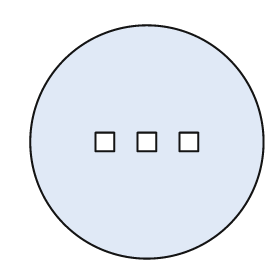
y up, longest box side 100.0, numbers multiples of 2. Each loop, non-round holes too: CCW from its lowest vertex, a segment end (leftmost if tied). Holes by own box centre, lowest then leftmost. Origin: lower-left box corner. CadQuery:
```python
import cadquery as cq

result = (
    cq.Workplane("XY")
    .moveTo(50.0, 50.0)
    .circle(50.0)
    .moveTo(28.0, 46.0)
    .lineTo(36.0, 46.0)
    .lineTo(36.0, 54.0)
    .lineTo(28.0, 54.0)
    .close()
    .moveTo(46.0, 46.0)
    .lineTo(54.0, 46.0)
    .lineTo(54.0, 54.0)
    .lineTo(46.0, 54.0)
    .close()
    .moveTo(64.0, 46.0)
    .lineTo(72.0, 46.0)
    .lineTo(72.0, 54.0)
    .lineTo(64.0, 54.0)
    .close()
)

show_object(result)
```